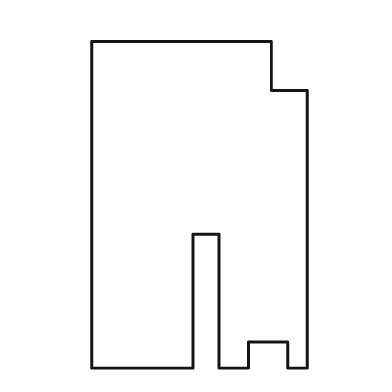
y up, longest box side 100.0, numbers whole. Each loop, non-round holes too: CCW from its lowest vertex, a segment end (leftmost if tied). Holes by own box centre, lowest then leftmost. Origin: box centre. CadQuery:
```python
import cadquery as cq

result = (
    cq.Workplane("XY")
    .moveTo(-33.0, -50.0)
    .lineTo(-2.0, -50.0)
    .lineTo(-2.0, -9.0)
    .lineTo(6.0, -9.0)
    .lineTo(6.0, -50.0)
    .lineTo(15.0, -50.0)
    .lineTo(15.0, -42.0)
    .lineTo(27.0, -42.0)
    .lineTo(27.0, -50.0)
    .lineTo(33.0, -50.0)
    .lineTo(33.0, 35.0)
    .lineTo(22.0, 35.0)
    .lineTo(22.0, 50.0)
    .lineTo(-33.0, 50.0)
    .close()
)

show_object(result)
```